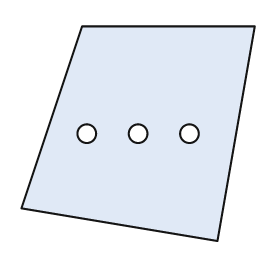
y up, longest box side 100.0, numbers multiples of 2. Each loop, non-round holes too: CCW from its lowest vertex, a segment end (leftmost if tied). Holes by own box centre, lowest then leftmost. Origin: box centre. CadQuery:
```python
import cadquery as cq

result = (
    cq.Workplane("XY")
    .moveTo(34.0, -46.0)
    .lineTo(50.0, 46.0)
    .lineTo(-24.0, 46.0)
    .lineTo(-50.0, -32.0)
    .close()
    .moveTo(-22.0, 0.0)
    .circle(4.0)
    .moveTo(0.0, 0.0)
    .circle(4.0)
    .moveTo(22.0, 0.0)
    .circle(4.0)
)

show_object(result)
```